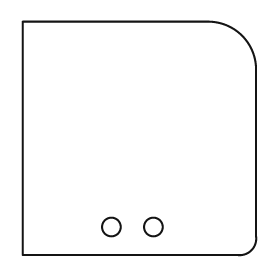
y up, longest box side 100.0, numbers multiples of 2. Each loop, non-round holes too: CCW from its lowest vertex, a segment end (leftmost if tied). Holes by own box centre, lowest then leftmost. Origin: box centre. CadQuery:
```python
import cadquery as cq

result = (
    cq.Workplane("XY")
    .moveTo(-50.0, -50.0)
    .lineTo(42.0, -50.0)
    .threePointArc((48.0, -48.0), (50.0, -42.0))
    .lineTo(50.0, 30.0)
    .threePointArc((44.0, 44.0), (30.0, 50.0))
    .lineTo(-50.0, 50.0)
    .close()
    .moveTo(-12.0, -38.0)
    .circle(4.0)
    .moveTo(6.0, -38.0)
    .circle(4.0)
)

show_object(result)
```